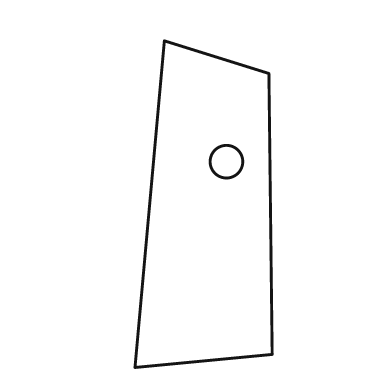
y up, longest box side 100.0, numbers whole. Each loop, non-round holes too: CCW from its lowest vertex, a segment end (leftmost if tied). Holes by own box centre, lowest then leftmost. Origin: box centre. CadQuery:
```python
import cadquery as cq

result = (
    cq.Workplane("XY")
    .moveTo(-21.0, -50.0)
    .lineTo(21.0, -46.0)
    .lineTo(20.0, 40.0)
    .lineTo(-12.0, 50.0)
    .close()
    .moveTo(7.0, 13.0)
    .circle(5.0)
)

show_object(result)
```